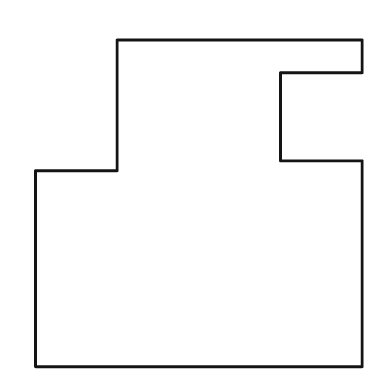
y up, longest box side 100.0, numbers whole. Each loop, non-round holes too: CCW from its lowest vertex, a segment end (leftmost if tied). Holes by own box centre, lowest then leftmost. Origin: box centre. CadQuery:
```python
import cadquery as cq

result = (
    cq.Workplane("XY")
    .moveTo(-50.0, -50.0)
    .lineTo(50.0, -50.0)
    .lineTo(50.0, 13.0)
    .lineTo(25.0, 13.0)
    .lineTo(25.0, 40.0)
    .lineTo(50.0, 40.0)
    .lineTo(50.0, 50.0)
    .lineTo(-25.0, 50.0)
    .lineTo(-25.0, 10.0)
    .lineTo(-50.0, 10.0)
    .close()
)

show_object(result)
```